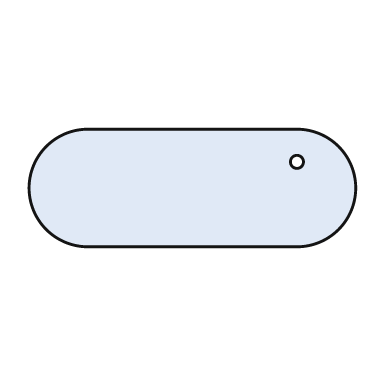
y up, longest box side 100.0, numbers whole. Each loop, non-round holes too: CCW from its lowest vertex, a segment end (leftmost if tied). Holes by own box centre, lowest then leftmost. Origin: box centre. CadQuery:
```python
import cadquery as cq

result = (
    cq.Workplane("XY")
    .moveTo(-32.0, -18.0)
    .lineTo(32.0, -18.0)
    .threePointArc((50.0, 0.0), (32.0, 18.0))
    .lineTo(-32.0, 18.0)
    .threePointArc((-50.0, 0.0), (-32.0, -18.0))
    .close()
    .moveTo(32.0, 8.0)
    .circle(2.0)
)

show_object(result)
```